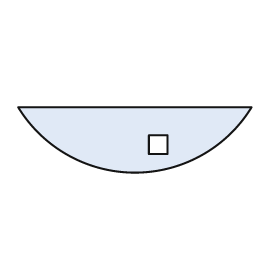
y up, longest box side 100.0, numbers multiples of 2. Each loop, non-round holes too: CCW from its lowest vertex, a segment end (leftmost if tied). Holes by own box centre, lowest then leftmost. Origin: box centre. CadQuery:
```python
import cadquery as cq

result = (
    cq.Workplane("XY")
    .moveTo(-50.0, 14.0)
    .threePointArc((0.0, -14.0), (50.0, 14.0))
    .close()
    .moveTo(6.0, -6.0)
    .lineTo(14.0, -6.0)
    .lineTo(14.0, 2.0)
    .lineTo(6.0, 2.0)
    .close()
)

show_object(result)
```